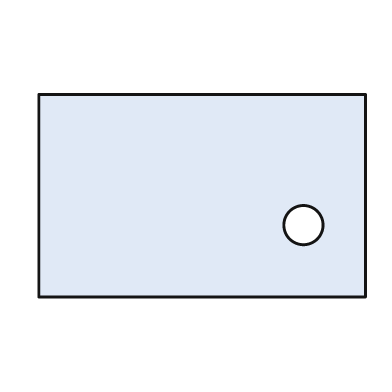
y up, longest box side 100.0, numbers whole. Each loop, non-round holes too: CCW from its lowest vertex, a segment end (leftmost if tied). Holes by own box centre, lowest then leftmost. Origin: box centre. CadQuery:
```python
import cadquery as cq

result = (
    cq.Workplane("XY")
    .moveTo(-50.0, -31.0)
    .lineTo(50.0, -31.0)
    .lineTo(50.0, 31.0)
    .lineTo(-50.0, 31.0)
    .close()
    .moveTo(31.0, -9.0)
    .circle(6.0)
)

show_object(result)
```